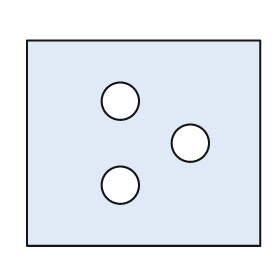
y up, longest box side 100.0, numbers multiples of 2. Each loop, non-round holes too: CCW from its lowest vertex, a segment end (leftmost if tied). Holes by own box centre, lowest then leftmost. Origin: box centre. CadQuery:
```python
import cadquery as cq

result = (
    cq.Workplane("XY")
    .moveTo(-50.0, -44.0)
    .lineTo(50.0, -44.0)
    .lineTo(50.0, 44.0)
    .lineTo(-50.0, 44.0)
    .close()
    .moveTo(-10.0, -18.0)
    .circle(8.0)
    .moveTo(20.0, 0.0)
    .circle(8.0)
    .moveTo(-10.0, 18.0)
    .circle(8.0)
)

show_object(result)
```